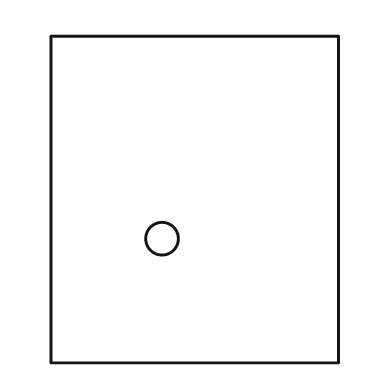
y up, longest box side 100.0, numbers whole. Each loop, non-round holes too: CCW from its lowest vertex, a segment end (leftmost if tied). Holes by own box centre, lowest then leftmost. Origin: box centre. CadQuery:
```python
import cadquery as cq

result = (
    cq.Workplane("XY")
    .moveTo(-44.0, -50.0)
    .lineTo(44.0, -50.0)
    .lineTo(44.0, 50.0)
    .lineTo(-44.0, 50.0)
    .close()
    .moveTo(-10.0, -12.0)
    .circle(5.0)
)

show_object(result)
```